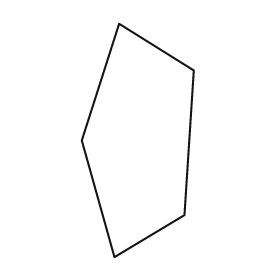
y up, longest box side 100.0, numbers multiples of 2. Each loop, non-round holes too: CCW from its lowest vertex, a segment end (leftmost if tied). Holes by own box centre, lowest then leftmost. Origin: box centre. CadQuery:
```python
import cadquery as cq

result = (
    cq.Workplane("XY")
    .moveTo(-10.0, -50.0)
    .lineTo(20.0, -32.0)
    .lineTo(24.0, 30.0)
    .lineTo(-8.0, 50.0)
    .lineTo(-24.0, 0.0)
    .close()
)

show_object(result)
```